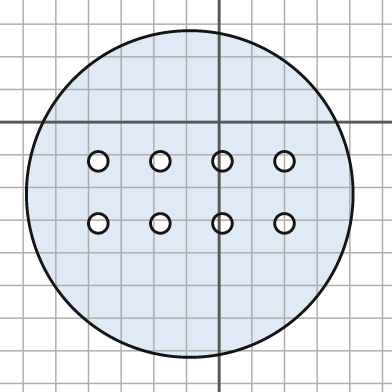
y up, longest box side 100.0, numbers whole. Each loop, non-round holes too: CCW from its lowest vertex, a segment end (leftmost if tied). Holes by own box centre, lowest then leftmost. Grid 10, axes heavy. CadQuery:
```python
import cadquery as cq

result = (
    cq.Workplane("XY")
    .moveTo(-9.0, -22.0)
    .circle(50.0)
    .moveTo(-37.0, -31.0)
    .circle(3.0)
    .moveTo(-18.0, -31.0)
    .circle(3.0)
    .moveTo(1.0, -31.0)
    .circle(3.0)
    .moveTo(20.0, -31.0)
    .circle(3.0)
    .moveTo(-37.0, -12.0)
    .circle(3.0)
    .moveTo(-18.0, -12.0)
    .circle(3.0)
    .moveTo(1.0, -12.0)
    .circle(3.0)
    .moveTo(20.0, -12.0)
    .circle(3.0)
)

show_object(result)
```